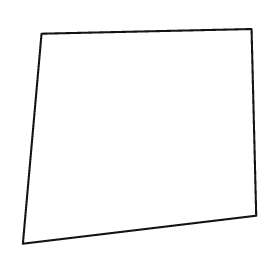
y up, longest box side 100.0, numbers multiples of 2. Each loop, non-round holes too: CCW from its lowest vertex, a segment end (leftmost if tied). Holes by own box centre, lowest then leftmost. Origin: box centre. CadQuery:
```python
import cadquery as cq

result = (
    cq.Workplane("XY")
    .moveTo(-50.0, -46.0)
    .lineTo(50.0, -34.0)
    .lineTo(48.0, 46.0)
    .lineTo(-42.0, 44.0)
    .close()
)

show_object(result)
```